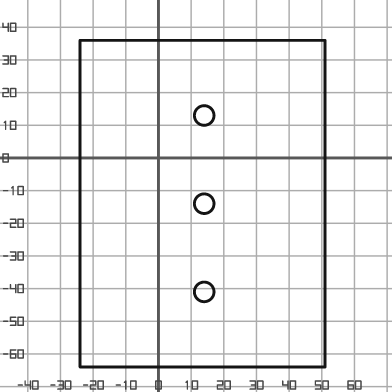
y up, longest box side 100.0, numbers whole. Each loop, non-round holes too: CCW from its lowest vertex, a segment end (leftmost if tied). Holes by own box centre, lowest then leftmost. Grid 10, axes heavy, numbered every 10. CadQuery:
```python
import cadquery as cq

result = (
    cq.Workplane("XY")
    .moveTo(-24.0, -64.0)
    .lineTo(51.0, -64.0)
    .lineTo(51.0, 36.0)
    .lineTo(-24.0, 36.0)
    .close()
    .moveTo(14.0, -41.0)
    .circle(3.0)
    .moveTo(14.0, -14.0)
    .circle(3.0)
    .moveTo(14.0, 13.0)
    .circle(3.0)
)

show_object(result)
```